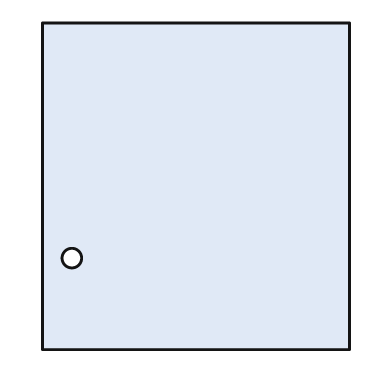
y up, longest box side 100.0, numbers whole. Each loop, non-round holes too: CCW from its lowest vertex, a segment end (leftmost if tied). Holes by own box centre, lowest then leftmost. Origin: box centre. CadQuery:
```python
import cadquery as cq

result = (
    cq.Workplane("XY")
    .moveTo(-47.0, -50.0)
    .lineTo(47.0, -50.0)
    .lineTo(47.0, 50.0)
    .lineTo(-47.0, 50.0)
    .close()
    .moveTo(-38.0, -22.0)
    .circle(3.0)
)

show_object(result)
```